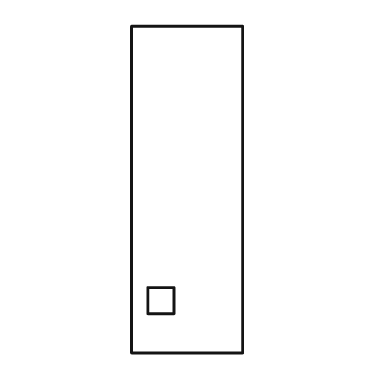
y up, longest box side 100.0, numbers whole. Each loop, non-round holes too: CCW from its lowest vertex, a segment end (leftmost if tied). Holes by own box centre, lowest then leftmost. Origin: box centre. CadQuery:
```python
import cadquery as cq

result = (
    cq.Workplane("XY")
    .moveTo(-17.0, -50.0)
    .lineTo(17.0, -50.0)
    .lineTo(17.0, 50.0)
    .lineTo(-17.0, 50.0)
    .close()
    .moveTo(-12.0, -38.0)
    .lineTo(-4.0, -38.0)
    .lineTo(-4.0, -30.0)
    .lineTo(-12.0, -30.0)
    .close()
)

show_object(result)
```